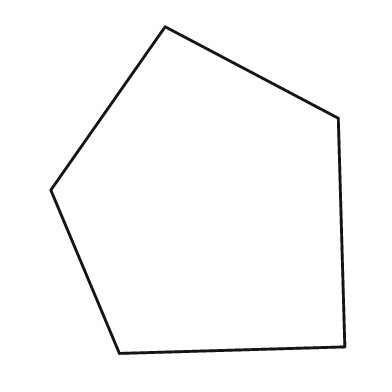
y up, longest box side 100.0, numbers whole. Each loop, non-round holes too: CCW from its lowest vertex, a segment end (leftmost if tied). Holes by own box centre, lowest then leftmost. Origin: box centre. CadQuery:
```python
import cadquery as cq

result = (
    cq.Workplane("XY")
    .moveTo(-24.0, -50.0)
    .lineTo(45.0, -48.0)
    .lineTo(43.0, 22.0)
    .lineTo(-10.0, 50.0)
    .lineTo(-45.0, 0.0)
    .close()
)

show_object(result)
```